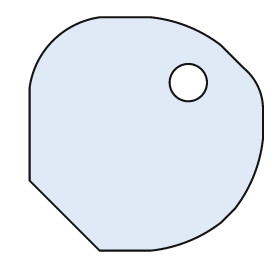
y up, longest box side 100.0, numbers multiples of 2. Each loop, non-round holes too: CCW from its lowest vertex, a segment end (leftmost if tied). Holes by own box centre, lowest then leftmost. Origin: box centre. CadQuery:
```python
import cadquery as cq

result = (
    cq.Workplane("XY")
    .moveTo(-20.0, -50.0)
    .lineTo(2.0, -50.0)
    .threePointArc((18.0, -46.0), (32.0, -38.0))
    .lineTo(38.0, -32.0)
    .threePointArc((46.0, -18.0), (50.0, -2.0))
    .lineTo(50.0, 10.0)
    .threePointArc((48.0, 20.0), (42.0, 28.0))
    .lineTo(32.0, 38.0)
    .threePointArc((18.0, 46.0), (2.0, 50.0))
    .lineTo(-20.0, 50.0)
    .threePointArc((-40.0, 40.0), (-50.0, 20.0))
    .lineTo(-50.0, -20.0)
    .close()
    .moveTo(18.0, 22.0)
    .circle(8.0)
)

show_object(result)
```